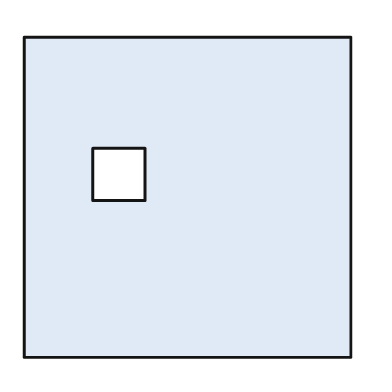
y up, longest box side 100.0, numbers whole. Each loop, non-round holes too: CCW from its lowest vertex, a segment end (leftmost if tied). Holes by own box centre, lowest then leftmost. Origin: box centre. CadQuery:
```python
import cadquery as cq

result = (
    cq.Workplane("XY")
    .moveTo(-50.0, -49.0)
    .lineTo(50.0, -49.0)
    .lineTo(50.0, 49.0)
    .lineTo(-50.0, 49.0)
    .close()
    .moveTo(-29.0, -1.0)
    .lineTo(-13.0, -1.0)
    .lineTo(-13.0, 15.0)
    .lineTo(-29.0, 15.0)
    .close()
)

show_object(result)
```